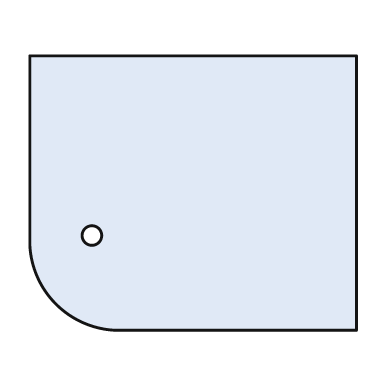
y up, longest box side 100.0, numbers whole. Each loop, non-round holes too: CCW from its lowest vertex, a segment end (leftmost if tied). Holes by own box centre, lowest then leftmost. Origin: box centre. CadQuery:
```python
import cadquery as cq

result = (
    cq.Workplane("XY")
    .moveTo(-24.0, -42.0)
    .lineTo(50.0, -42.0)
    .lineTo(50.0, 42.0)
    .lineTo(-50.0, 42.0)
    .lineTo(-50.0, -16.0)
    .threePointArc((-42.0, -34.0), (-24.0, -42.0))
    .close()
    .moveTo(-31.0, -13.0)
    .circle(3.0)
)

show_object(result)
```